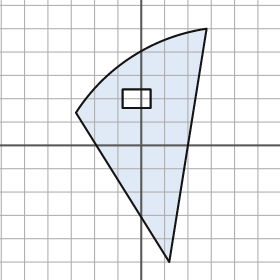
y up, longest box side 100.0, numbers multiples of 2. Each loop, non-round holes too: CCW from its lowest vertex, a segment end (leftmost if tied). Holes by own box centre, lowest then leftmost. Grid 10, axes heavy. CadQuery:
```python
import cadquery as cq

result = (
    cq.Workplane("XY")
    .moveTo(12.0, -50.0)
    .lineTo(28.0, 50.0)
    .threePointArc((-4.0, 38.0), (-28.0, 14.0))
    .close()
    .moveTo(-8.0, 16.0)
    .lineTo(4.0, 16.0)
    .lineTo(4.0, 24.0)
    .lineTo(-8.0, 24.0)
    .close()
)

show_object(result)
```